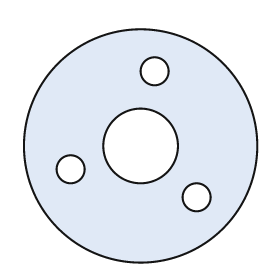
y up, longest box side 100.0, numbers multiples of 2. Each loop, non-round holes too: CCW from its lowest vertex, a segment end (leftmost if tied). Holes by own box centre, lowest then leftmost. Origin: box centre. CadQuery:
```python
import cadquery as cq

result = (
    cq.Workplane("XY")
    .moveTo(0.0, 0.0)
    .circle(50.0)
    .moveTo(24.0, -22.0)
    .circle(6.0)
    .moveTo(-30.0, -10.0)
    .circle(6.0)
    .moveTo(0.0, 0.0)
    .circle(16.0)
    .moveTo(6.0, 32.0)
    .circle(6.0)
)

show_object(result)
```